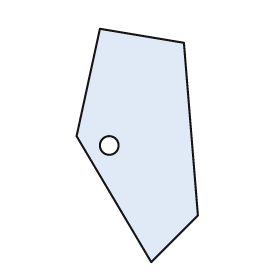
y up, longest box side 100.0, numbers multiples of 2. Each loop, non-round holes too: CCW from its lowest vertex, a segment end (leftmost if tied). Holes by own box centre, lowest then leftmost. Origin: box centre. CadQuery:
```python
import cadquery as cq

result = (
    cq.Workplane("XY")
    .moveTo(6.0, -50.0)
    .lineTo(26.0, -30.0)
    .lineTo(20.0, 44.0)
    .lineTo(-16.0, 50.0)
    .lineTo(-26.0, 4.0)
    .close()
    .moveTo(-12.0, 0.0)
    .circle(4.0)
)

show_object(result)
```